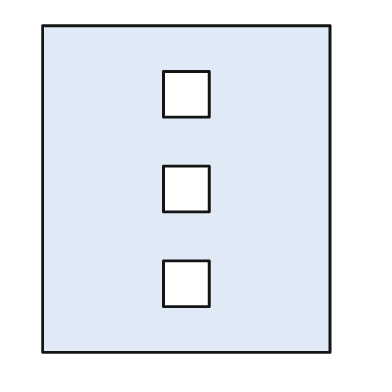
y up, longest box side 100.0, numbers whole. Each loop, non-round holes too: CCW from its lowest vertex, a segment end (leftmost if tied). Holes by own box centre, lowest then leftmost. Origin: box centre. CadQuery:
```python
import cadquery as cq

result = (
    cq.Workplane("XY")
    .moveTo(-44.0, -50.0)
    .lineTo(44.0, -50.0)
    .lineTo(44.0, 50.0)
    .lineTo(-44.0, 50.0)
    .close()
    .moveTo(-7.0, -36.0)
    .lineTo(7.0, -36.0)
    .lineTo(7.0, -22.0)
    .lineTo(-7.0, -22.0)
    .close()
    .moveTo(-7.0, -7.0)
    .lineTo(7.0, -7.0)
    .lineTo(7.0, 7.0)
    .lineTo(-7.0, 7.0)
    .close()
    .moveTo(-7.0, 22.0)
    .lineTo(7.0, 22.0)
    .lineTo(7.0, 36.0)
    .lineTo(-7.0, 36.0)
    .close()
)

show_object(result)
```